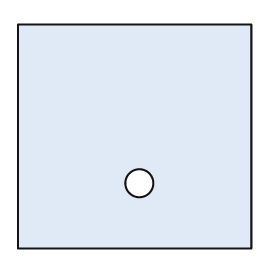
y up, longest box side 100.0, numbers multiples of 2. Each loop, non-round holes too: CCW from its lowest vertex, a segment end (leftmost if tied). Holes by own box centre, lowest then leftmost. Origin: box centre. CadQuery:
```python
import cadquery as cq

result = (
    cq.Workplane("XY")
    .moveTo(-50.0, -48.0)
    .lineTo(50.0, -48.0)
    .lineTo(50.0, 48.0)
    .lineTo(-50.0, 48.0)
    .close()
    .moveTo(2.0, -20.0)
    .circle(6.0)
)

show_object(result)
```